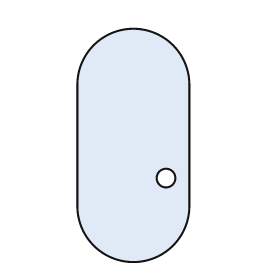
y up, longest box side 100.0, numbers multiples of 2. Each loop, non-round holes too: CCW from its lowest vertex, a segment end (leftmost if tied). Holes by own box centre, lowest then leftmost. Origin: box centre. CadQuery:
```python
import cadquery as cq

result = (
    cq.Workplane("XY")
    .moveTo(-24.0, -26.0)
    .threePointArc((0.0, -50.0), (24.0, -26.0))
    .lineTo(24.0, 26.0)
    .threePointArc((0.0, 50.0), (-24.0, 26.0))
    .close()
    .moveTo(14.0, -14.0)
    .circle(4.0)
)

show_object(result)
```